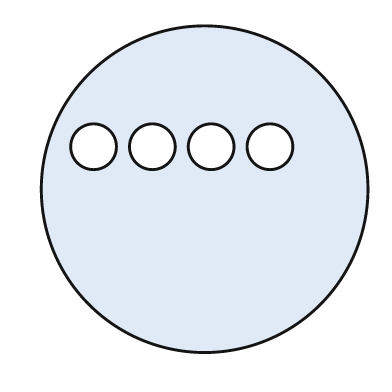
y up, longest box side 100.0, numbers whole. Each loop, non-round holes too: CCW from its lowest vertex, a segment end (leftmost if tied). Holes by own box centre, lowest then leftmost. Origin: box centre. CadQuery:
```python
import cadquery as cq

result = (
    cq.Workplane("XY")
    .moveTo(0.0, 0.0)
    .circle(50.0)
    .moveTo(-34.0, 13.0)
    .circle(7.0)
    .moveTo(-16.0, 13.0)
    .circle(7.0)
    .moveTo(2.0, 13.0)
    .circle(7.0)
    .moveTo(20.0, 13.0)
    .circle(7.0)
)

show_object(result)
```